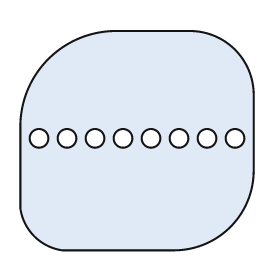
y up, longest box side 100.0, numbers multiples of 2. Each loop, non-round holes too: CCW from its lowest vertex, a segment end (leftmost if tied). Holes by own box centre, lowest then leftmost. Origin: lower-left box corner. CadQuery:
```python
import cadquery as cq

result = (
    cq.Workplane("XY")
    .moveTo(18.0, 0.0)
    .lineTo(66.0, 0.0)
    .threePointArc((90.0, 10.0), (100.0, 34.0))
    .lineTo(100.0, 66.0)
    .threePointArc((92.0, 86.0), (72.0, 94.0))
    .lineTo(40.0, 94.0)
    .threePointArc((12.0, 82.0), (0.0, 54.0))
    .lineTo(0.0, 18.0)
    .threePointArc((6.0, 6.0), (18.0, 0.0))
    .close()
    .moveTo(8.0, 48.0)
    .circle(4.0)
    .moveTo(20.0, 48.0)
    .circle(4.0)
    .moveTo(32.0, 48.0)
    .circle(4.0)
    .moveTo(44.0, 48.0)
    .circle(4.0)
    .moveTo(56.0, 48.0)
    .circle(4.0)
    .moveTo(68.0, 48.0)
    .circle(4.0)
    .moveTo(80.0, 48.0)
    .circle(4.0)
    .moveTo(92.0, 48.0)
    .circle(4.0)
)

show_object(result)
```